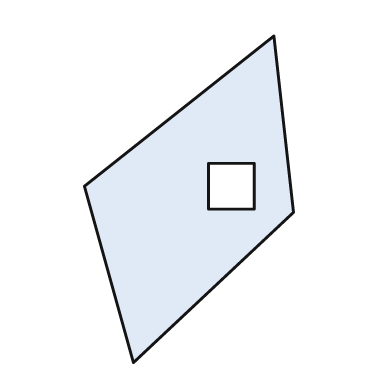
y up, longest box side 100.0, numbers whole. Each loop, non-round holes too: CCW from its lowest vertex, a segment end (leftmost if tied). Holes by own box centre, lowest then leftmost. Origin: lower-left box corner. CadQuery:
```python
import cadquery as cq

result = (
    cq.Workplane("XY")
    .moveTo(15.0, 0.0)
    .lineTo(64.0, 46.0)
    .lineTo(58.0, 100.0)
    .lineTo(0.0, 54.0)
    .close()
    .moveTo(38.0, 47.0)
    .lineTo(52.0, 47.0)
    .lineTo(52.0, 61.0)
    .lineTo(38.0, 61.0)
    .close()
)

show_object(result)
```